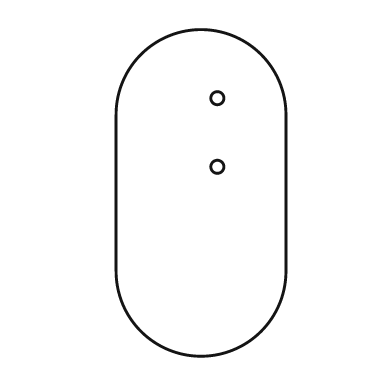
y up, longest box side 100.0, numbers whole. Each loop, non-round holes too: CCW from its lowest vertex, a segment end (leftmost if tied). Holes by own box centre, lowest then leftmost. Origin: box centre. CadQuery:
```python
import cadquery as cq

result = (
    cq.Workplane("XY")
    .moveTo(-26.0, -24.0)
    .threePointArc((0.0, -50.0), (26.0, -24.0))
    .lineTo(26.0, 24.0)
    .threePointArc((0.0, 50.0), (-26.0, 24.0))
    .close()
    .moveTo(5.0, 8.0)
    .circle(2.0)
    .moveTo(5.0, 29.0)
    .circle(2.0)
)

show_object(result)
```